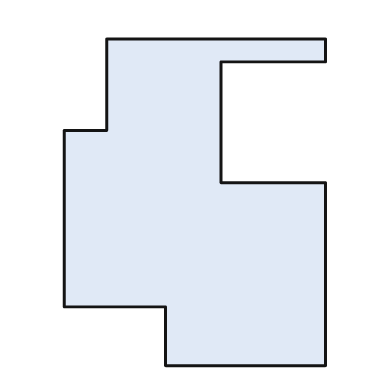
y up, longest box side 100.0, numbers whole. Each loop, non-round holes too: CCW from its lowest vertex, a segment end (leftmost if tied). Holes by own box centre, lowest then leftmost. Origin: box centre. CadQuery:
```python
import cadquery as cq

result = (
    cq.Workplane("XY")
    .moveTo(-9.0, -50.0)
    .lineTo(40.0, -50.0)
    .lineTo(40.0, 6.0)
    .lineTo(8.0, 6.0)
    .lineTo(8.0, 43.0)
    .lineTo(40.0, 43.0)
    .lineTo(40.0, 50.0)
    .lineTo(-27.0, 50.0)
    .lineTo(-27.0, 22.0)
    .lineTo(-40.0, 22.0)
    .lineTo(-40.0, -32.0)
    .lineTo(-9.0, -32.0)
    .close()
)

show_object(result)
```